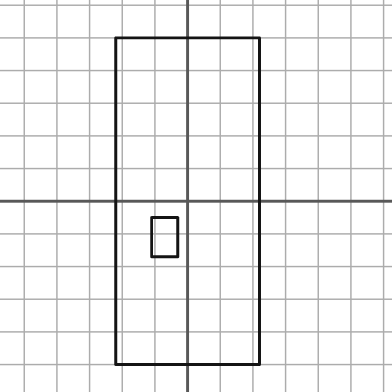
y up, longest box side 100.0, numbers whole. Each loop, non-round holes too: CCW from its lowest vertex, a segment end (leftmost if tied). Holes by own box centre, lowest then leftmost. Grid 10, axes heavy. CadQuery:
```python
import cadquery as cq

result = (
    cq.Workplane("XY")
    .moveTo(-22.0, -50.0)
    .lineTo(22.0, -50.0)
    .lineTo(22.0, 50.0)
    .lineTo(-22.0, 50.0)
    .close()
    .moveTo(-11.0, -17.0)
    .lineTo(-3.0, -17.0)
    .lineTo(-3.0, -5.0)
    .lineTo(-11.0, -5.0)
    .close()
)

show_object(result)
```